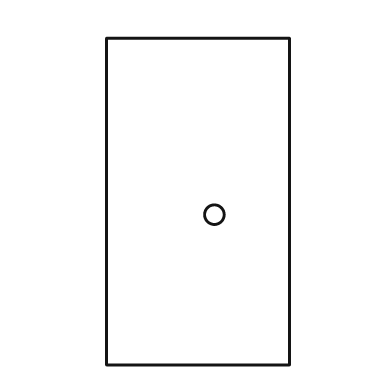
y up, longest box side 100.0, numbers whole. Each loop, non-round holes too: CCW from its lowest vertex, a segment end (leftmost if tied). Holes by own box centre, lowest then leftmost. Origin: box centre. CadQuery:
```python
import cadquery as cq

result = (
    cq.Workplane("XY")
    .moveTo(-28.0, -50.0)
    .lineTo(28.0, -50.0)
    .lineTo(28.0, 50.0)
    .lineTo(-28.0, 50.0)
    .close()
    .moveTo(5.0, -4.0)
    .circle(3.0)
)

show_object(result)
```